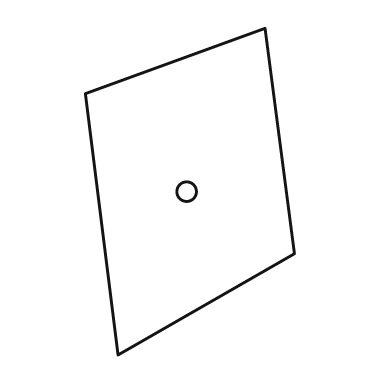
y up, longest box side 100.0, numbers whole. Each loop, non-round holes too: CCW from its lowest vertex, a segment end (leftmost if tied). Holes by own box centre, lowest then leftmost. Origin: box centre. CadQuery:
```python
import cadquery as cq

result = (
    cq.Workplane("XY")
    .moveTo(-22.0, -50.0)
    .lineTo(32.0, -19.0)
    .lineTo(23.0, 50.0)
    .lineTo(-32.0, 30.0)
    .close()
    .moveTo(-1.0, 0.0)
    .circle(3.0)
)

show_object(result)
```